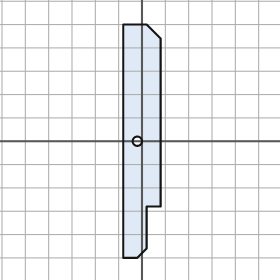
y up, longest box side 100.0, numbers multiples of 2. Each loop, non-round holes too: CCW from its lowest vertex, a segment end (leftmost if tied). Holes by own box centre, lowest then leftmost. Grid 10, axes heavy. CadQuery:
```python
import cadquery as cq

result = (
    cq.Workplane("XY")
    .moveTo(-8.0, -50.0)
    .lineTo(-2.0, -50.0)
    .lineTo(2.0, -46.0)
    .lineTo(2.0, -28.0)
    .lineTo(8.0, -28.0)
    .lineTo(8.0, 44.0)
    .lineTo(2.0, 50.0)
    .lineTo(-8.0, 50.0)
    .close()
    .moveTo(-2.0, 0.0)
    .circle(2.0)
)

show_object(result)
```